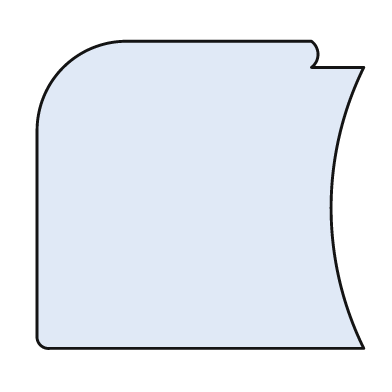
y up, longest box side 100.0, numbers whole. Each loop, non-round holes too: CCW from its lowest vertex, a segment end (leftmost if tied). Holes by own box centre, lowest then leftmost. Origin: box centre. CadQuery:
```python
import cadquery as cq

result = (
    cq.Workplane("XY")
    .moveTo(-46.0, -47.0)
    .lineTo(50.0, -47.0)
    .threePointArc((40.0, -4.0), (50.0, 39.0))
    .lineTo(34.0, 39.0)
    .threePointArc((36.0, 43.0), (34.0, 47.0))
    .lineTo(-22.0, 47.0)
    .threePointArc((-42.0, 39.0), (-50.0, 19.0))
    .lineTo(-50.0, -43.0)
    .threePointArc((-49.0, -46.0), (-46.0, -47.0))
    .close()
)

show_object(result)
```